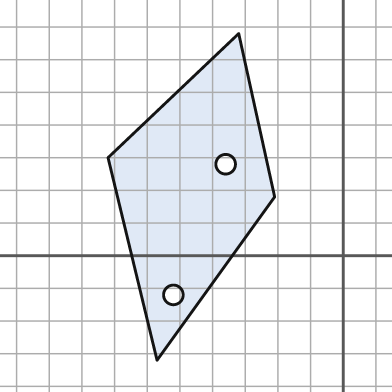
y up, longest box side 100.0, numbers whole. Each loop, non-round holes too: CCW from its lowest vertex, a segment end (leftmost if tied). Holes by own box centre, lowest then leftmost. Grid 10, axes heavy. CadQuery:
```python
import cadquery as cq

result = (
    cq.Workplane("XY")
    .moveTo(-57.0, -32.0)
    .lineTo(-21.0, 18.0)
    .lineTo(-32.0, 68.0)
    .lineTo(-72.0, 30.0)
    .close()
    .moveTo(-52.0, -12.0)
    .circle(3.0)
    .moveTo(-36.0, 28.0)
    .circle(3.0)
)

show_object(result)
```